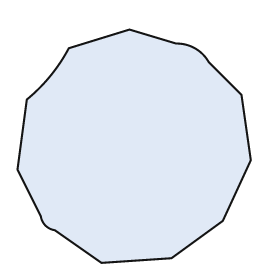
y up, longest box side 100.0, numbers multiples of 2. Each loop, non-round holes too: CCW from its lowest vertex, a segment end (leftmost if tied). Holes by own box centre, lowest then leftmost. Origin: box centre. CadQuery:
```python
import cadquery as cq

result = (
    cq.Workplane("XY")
    .moveTo(-14.0, -50.0)
    .lineTo(16.0, -48.0)
    .lineTo(38.0, -32.0)
    .lineTo(50.0, -6.0)
    .lineTo(46.0, 22.0)
    .lineTo(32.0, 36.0)
    .threePointArc((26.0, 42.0), (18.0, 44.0))
    .lineTo(-2.0, 50.0)
    .lineTo(-28.0, 42.0)
    .threePointArc((-36.0, 30.0), (-46.0, 20.0))
    .lineTo(-50.0, -10.0)
    .lineTo(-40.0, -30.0)
    .threePointArc((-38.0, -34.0), (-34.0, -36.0))
    .close()
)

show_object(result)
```